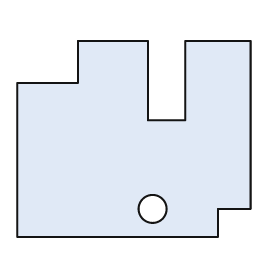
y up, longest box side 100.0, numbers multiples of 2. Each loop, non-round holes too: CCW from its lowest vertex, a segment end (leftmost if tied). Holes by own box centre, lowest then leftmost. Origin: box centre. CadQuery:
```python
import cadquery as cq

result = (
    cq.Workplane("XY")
    .moveTo(-50.0, -42.0)
    .lineTo(36.0, -42.0)
    .lineTo(36.0, -30.0)
    .lineTo(50.0, -30.0)
    .lineTo(50.0, 42.0)
    .lineTo(22.0, 42.0)
    .lineTo(22.0, 8.0)
    .lineTo(6.0, 8.0)
    .lineTo(6.0, 42.0)
    .lineTo(-24.0, 42.0)
    .lineTo(-24.0, 24.0)
    .lineTo(-50.0, 24.0)
    .close()
    .moveTo(8.0, -30.0)
    .circle(6.0)
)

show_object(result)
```